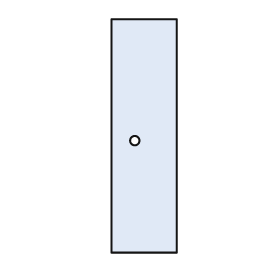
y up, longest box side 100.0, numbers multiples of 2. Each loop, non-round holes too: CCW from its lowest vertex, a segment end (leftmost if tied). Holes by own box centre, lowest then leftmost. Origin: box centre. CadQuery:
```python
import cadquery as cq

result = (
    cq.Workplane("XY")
    .moveTo(-14.0, -50.0)
    .lineTo(14.0, -50.0)
    .lineTo(14.0, 50.0)
    .lineTo(-14.0, 50.0)
    .close()
    .moveTo(-4.0, -2.0)
    .circle(2.0)
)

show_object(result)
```